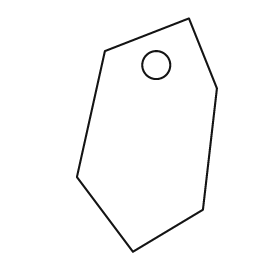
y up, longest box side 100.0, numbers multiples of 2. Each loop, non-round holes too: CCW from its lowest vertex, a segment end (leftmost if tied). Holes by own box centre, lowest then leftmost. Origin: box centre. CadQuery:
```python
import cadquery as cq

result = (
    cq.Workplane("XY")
    .moveTo(-6.0, -50.0)
    .lineTo(24.0, -32.0)
    .lineTo(30.0, 20.0)
    .lineTo(18.0, 50.0)
    .lineTo(-18.0, 36.0)
    .lineTo(-30.0, -18.0)
    .close()
    .moveTo(4.0, 30.0)
    .circle(6.0)
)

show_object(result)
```